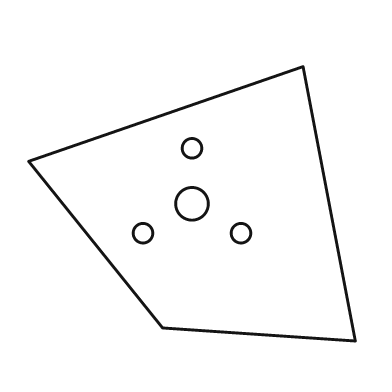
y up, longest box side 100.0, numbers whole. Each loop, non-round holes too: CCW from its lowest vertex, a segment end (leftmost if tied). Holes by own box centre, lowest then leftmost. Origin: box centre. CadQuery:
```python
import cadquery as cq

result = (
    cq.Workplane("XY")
    .moveTo(50.0, -42.0)
    .lineTo(34.0, 42.0)
    .lineTo(-50.0, 13.0)
    .lineTo(-9.0, -38.0)
    .close()
    .moveTo(-15.0, -9.0)
    .circle(3.0)
    .moveTo(15.0, -9.0)
    .circle(3.0)
    .moveTo(0.0, 0.0)
    .circle(5.0)
    .moveTo(0.0, 17.0)
    .circle(3.0)
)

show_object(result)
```